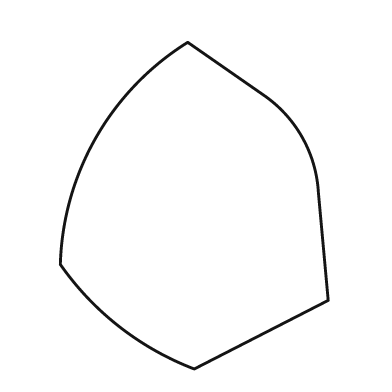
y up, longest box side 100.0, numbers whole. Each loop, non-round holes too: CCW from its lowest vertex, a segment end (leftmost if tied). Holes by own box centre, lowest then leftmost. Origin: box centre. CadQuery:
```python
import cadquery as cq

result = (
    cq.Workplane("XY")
    .moveTo(0.0, -50.0)
    .lineTo(41.0, -29.0)
    .lineTo(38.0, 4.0)
    .threePointArc((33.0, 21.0), (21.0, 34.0))
    .lineTo(-2.0, 50.0)
    .threePointArc((-30.0, 21.0), (-41.0, -18.0))
    .threePointArc((-23.0, -37.0), (0.0, -50.0))
    .close()
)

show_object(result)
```